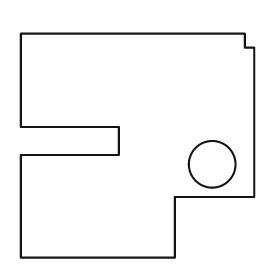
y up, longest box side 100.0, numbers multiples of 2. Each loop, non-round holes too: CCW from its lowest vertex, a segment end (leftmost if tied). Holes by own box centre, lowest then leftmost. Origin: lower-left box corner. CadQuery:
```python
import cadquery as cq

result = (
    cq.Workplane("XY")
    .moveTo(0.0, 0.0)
    .lineTo(66.0, 0.0)
    .lineTo(66.0, 26.0)
    .lineTo(100.0, 26.0)
    .lineTo(100.0, 90.0)
    .lineTo(96.0, 90.0)
    .lineTo(96.0, 96.0)
    .lineTo(0.0, 96.0)
    .lineTo(0.0, 56.0)
    .lineTo(42.0, 56.0)
    .lineTo(42.0, 44.0)
    .lineTo(0.0, 44.0)
    .close()
    .moveTo(82.0, 40.0)
    .circle(10.0)
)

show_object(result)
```